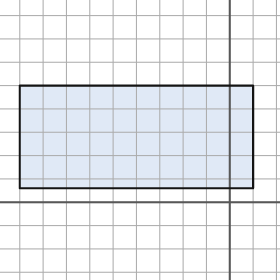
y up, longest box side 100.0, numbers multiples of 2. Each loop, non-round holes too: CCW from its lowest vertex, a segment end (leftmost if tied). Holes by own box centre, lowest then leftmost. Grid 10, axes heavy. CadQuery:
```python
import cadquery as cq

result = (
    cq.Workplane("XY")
    .moveTo(-90.0, 6.0)
    .lineTo(10.0, 6.0)
    .lineTo(10.0, 50.0)
    .lineTo(-90.0, 50.0)
    .close()
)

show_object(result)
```